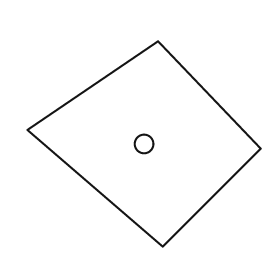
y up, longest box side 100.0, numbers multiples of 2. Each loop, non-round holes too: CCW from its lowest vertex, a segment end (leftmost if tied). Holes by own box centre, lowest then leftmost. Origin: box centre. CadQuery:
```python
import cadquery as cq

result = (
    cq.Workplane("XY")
    .moveTo(8.0, -44.0)
    .lineTo(50.0, -2.0)
    .lineTo(6.0, 44.0)
    .lineTo(-50.0, 6.0)
    .close()
    .moveTo(0.0, 0.0)
    .circle(4.0)
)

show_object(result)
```